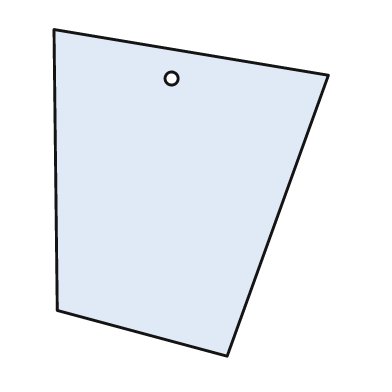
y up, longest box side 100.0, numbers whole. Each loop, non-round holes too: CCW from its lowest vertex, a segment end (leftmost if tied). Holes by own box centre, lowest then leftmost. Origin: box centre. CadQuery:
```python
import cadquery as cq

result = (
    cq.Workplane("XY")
    .moveTo(11.0, -50.0)
    .lineTo(42.0, 36.0)
    .lineTo(-42.0, 50.0)
    .lineTo(-41.0, -36.0)
    .close()
    .moveTo(-6.0, 35.0)
    .circle(2.0)
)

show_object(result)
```